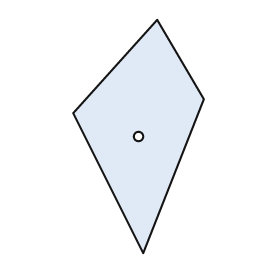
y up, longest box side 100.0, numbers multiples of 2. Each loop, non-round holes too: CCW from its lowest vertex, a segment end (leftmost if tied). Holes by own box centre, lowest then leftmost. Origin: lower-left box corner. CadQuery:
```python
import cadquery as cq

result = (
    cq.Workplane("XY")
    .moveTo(30.0, 0.0)
    .lineTo(56.0, 66.0)
    .lineTo(36.0, 100.0)
    .lineTo(0.0, 60.0)
    .close()
    .moveTo(28.0, 50.0)
    .circle(2.0)
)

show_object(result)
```